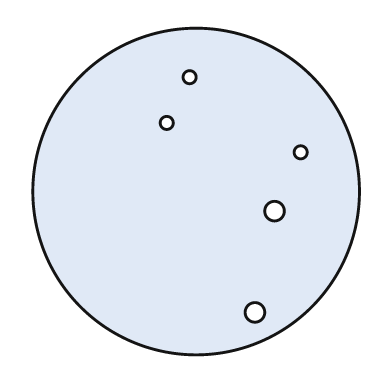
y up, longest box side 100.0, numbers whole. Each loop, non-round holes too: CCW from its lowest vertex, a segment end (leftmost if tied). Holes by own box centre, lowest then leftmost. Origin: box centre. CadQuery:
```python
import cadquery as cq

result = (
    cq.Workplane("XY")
    .moveTo(0.0, 0.0)
    .circle(50.0)
    .moveTo(18.0, -37.0)
    .circle(3.0)
    .moveTo(24.0, -6.0)
    .circle(3.0)
    .moveTo(32.0, 12.0)
    .circle(2.0)
    .moveTo(-9.0, 21.0)
    .circle(2.0)
    .moveTo(-2.0, 35.0)
    .circle(2.0)
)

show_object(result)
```